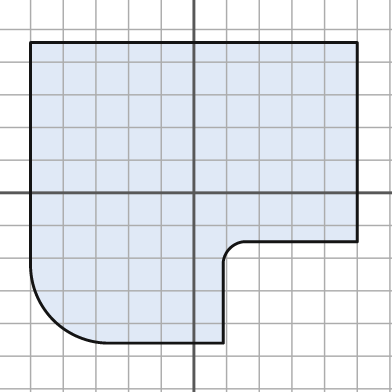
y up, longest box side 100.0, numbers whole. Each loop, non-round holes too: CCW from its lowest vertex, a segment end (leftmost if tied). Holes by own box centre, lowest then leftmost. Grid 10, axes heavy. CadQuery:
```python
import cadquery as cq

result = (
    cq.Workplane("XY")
    .moveTo(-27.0, -46.0)
    .lineTo(9.0, -46.0)
    .lineTo(9.0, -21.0)
    .threePointArc((11.0, -17.0), (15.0, -15.0))
    .lineTo(50.0, -15.0)
    .lineTo(50.0, 46.0)
    .lineTo(-50.0, 46.0)
    .lineTo(-50.0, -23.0)
    .threePointArc((-43.0, -39.0), (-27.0, -46.0))
    .close()
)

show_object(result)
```